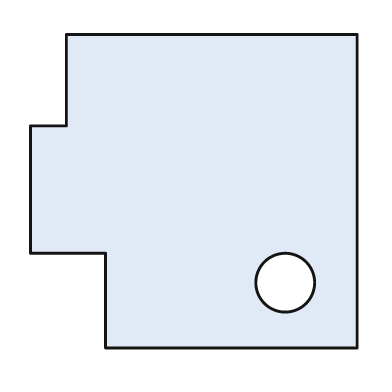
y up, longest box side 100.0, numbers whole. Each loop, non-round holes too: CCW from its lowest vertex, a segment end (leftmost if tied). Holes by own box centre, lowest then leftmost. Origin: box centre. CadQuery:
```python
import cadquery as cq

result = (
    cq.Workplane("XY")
    .moveTo(-27.0, -48.0)
    .lineTo(50.0, -48.0)
    .lineTo(50.0, 48.0)
    .lineTo(-39.0, 48.0)
    .lineTo(-39.0, 20.0)
    .lineTo(-50.0, 20.0)
    .lineTo(-50.0, -19.0)
    .lineTo(-27.0, -19.0)
    .close()
    .moveTo(28.0, -28.0)
    .circle(9.0)
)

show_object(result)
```